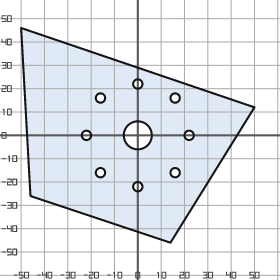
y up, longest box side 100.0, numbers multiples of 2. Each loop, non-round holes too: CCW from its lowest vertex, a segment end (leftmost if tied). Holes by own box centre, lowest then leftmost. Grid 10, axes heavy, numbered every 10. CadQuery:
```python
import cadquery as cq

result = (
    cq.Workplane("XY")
    .moveTo(14.0, -46.0)
    .lineTo(50.0, 12.0)
    .lineTo(-50.0, 46.0)
    .lineTo(-46.0, -26.0)
    .close()
    .moveTo(0.0, -22.0)
    .circle(2.0)
    .moveTo(-16.0, -16.0)
    .circle(2.0)
    .moveTo(16.0, -16.0)
    .circle(2.0)
    .moveTo(-22.0, 0.0)
    .circle(2.0)
    .moveTo(0.0, 0.0)
    .circle(6.0)
    .moveTo(22.0, 0.0)
    .circle(2.0)
    .moveTo(-16.0, 16.0)
    .circle(2.0)
    .moveTo(16.0, 16.0)
    .circle(2.0)
    .moveTo(0.0, 22.0)
    .circle(2.0)
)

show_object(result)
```